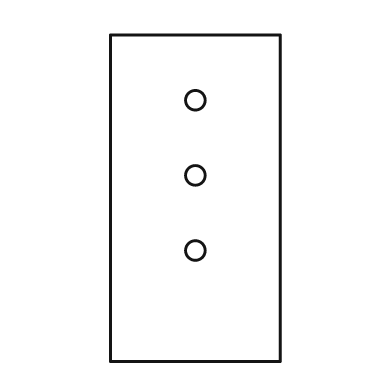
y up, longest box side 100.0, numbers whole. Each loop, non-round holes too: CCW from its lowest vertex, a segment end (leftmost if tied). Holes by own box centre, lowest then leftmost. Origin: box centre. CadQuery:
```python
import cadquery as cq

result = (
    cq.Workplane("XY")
    .moveTo(-26.0, -50.0)
    .lineTo(26.0, -50.0)
    .lineTo(26.0, 50.0)
    .lineTo(-26.0, 50.0)
    .close()
    .moveTo(0.0, -16.0)
    .circle(3.0)
    .moveTo(0.0, 7.0)
    .circle(3.0)
    .moveTo(0.0, 30.0)
    .circle(3.0)
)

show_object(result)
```